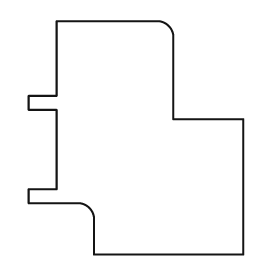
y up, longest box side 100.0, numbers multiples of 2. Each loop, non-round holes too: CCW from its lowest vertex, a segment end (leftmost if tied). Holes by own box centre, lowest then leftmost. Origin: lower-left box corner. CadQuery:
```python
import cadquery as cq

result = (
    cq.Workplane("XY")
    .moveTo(28.0, 0.0)
    .lineTo(92.0, 0.0)
    .lineTo(92.0, 58.0)
    .lineTo(62.0, 58.0)
    .lineTo(62.0, 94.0)
    .threePointArc((60.0, 98.0), (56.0, 100.0))
    .lineTo(12.0, 100.0)
    .lineTo(12.0, 68.0)
    .lineTo(0.0, 68.0)
    .lineTo(0.0, 62.0)
    .lineTo(12.0, 62.0)
    .lineTo(12.0, 28.0)
    .lineTo(0.0, 28.0)
    .lineTo(0.0, 22.0)
    .lineTo(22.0, 22.0)
    .threePointArc((26.0, 20.0), (28.0, 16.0))
    .close()
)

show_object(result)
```